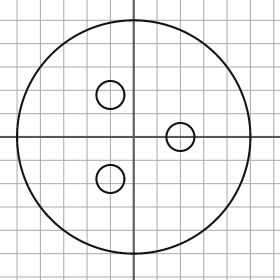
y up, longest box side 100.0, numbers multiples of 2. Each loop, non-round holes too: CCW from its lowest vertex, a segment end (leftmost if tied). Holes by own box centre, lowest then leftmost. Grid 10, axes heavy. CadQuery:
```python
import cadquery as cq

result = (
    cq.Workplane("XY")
    .moveTo(0.0, 0.0)
    .circle(50.0)
    .moveTo(-10.0, -18.0)
    .circle(6.0)
    .moveTo(20.0, 0.0)
    .circle(6.0)
    .moveTo(-10.0, 18.0)
    .circle(6.0)
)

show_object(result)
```